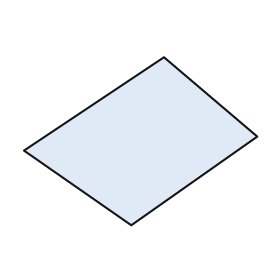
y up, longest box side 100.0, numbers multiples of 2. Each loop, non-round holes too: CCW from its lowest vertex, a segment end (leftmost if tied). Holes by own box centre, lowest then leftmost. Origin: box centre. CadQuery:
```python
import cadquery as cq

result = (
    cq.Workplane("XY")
    .moveTo(-4.0, -36.0)
    .lineTo(50.0, 2.0)
    .lineTo(10.0, 36.0)
    .lineTo(-50.0, -4.0)
    .close()
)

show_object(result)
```